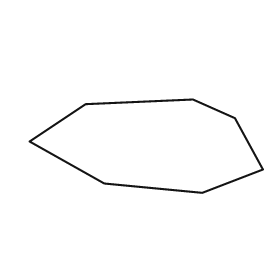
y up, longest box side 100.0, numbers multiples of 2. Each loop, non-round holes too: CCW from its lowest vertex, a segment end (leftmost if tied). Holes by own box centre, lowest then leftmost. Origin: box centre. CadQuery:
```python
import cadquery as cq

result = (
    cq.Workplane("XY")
    .moveTo(24.0, -20.0)
    .lineTo(50.0, -10.0)
    .lineTo(38.0, 12.0)
    .lineTo(20.0, 20.0)
    .lineTo(-26.0, 18.0)
    .lineTo(-50.0, 2.0)
    .lineTo(-18.0, -16.0)
    .close()
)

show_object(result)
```